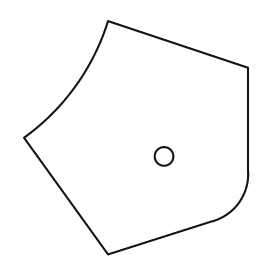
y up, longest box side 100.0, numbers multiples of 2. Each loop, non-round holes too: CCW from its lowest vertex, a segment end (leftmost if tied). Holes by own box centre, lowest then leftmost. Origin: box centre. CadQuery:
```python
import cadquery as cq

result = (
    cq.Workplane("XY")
    .moveTo(-12.0, -50.0)
    .lineTo(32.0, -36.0)
    .threePointArc((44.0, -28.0), (48.0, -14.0))
    .lineTo(48.0, 30.0)
    .lineTo(-12.0, 50.0)
    .threePointArc((-26.0, 22.0), (-48.0, 0.0))
    .close()
    .moveTo(12.0, -8.0)
    .circle(4.0)
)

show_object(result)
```